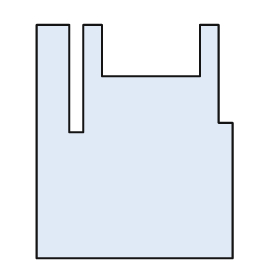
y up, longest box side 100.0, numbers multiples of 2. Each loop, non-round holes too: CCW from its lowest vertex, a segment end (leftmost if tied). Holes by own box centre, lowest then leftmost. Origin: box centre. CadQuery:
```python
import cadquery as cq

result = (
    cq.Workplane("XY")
    .moveTo(-42.0, -50.0)
    .lineTo(42.0, -50.0)
    .lineTo(42.0, 8.0)
    .lineTo(36.0, 8.0)
    .lineTo(36.0, 50.0)
    .lineTo(28.0, 50.0)
    .lineTo(28.0, 28.0)
    .lineTo(-14.0, 28.0)
    .lineTo(-14.0, 50.0)
    .lineTo(-22.0, 50.0)
    .lineTo(-22.0, 4.0)
    .lineTo(-28.0, 4.0)
    .lineTo(-28.0, 50.0)
    .lineTo(-42.0, 50.0)
    .close()
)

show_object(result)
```